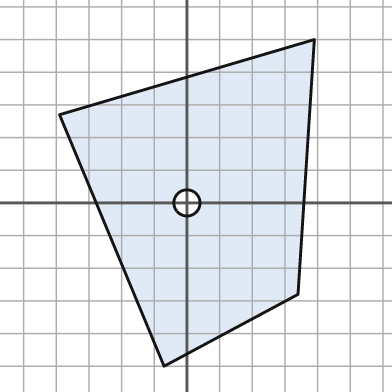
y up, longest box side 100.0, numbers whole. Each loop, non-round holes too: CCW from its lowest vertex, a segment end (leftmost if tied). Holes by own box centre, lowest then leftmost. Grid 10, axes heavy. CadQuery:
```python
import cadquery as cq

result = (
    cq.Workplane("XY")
    .moveTo(-7.0, -50.0)
    .lineTo(34.0, -28.0)
    .lineTo(39.0, 50.0)
    .lineTo(-39.0, 27.0)
    .close()
    .moveTo(0.0, 0.0)
    .circle(4.0)
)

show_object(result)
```